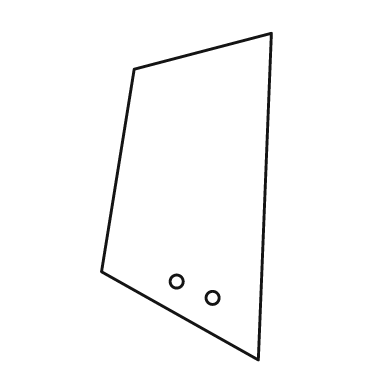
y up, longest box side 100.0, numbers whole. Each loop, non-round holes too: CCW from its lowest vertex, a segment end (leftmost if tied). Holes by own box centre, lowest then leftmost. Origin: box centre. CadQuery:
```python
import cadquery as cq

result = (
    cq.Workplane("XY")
    .moveTo(22.0, -50.0)
    .lineTo(26.0, 50.0)
    .lineTo(-16.0, 39.0)
    .lineTo(-26.0, -23.0)
    .close()
    .moveTo(8.0, -31.0)
    .circle(2.0)
    .moveTo(-3.0, -26.0)
    .circle(2.0)
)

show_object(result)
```